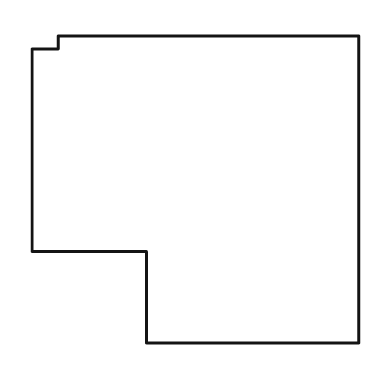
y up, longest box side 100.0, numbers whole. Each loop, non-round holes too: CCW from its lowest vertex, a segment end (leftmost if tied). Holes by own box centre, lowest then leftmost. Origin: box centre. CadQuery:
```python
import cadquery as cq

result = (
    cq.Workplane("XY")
    .moveTo(-15.0, -47.0)
    .lineTo(50.0, -47.0)
    .lineTo(50.0, 47.0)
    .lineTo(-42.0, 47.0)
    .lineTo(-42.0, 43.0)
    .lineTo(-50.0, 43.0)
    .lineTo(-50.0, -19.0)
    .lineTo(-15.0, -19.0)
    .close()
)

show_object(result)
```